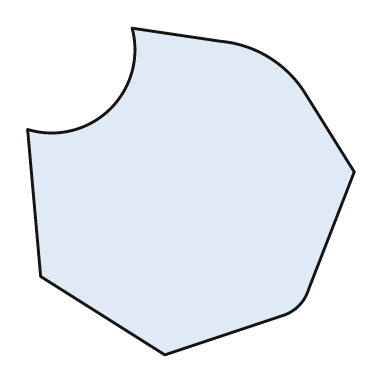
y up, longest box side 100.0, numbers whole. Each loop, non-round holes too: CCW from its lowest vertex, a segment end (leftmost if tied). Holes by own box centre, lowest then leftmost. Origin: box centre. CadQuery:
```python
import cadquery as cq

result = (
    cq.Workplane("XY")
    .moveTo(-8.0, -50.0)
    .lineTo(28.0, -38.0)
    .threePointArc((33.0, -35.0), (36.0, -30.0))
    .lineTo(50.0, 6.0)
    .lineTo(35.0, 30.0)
    .threePointArc((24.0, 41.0), (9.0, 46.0))
    .lineTo(-18.0, 50.0)
    .threePointArc((-25.0, 25.0), (-50.0, 19.0))
    .lineTo(-46.0, -26.0)
    .close()
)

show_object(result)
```